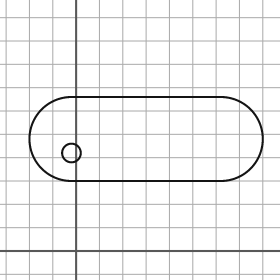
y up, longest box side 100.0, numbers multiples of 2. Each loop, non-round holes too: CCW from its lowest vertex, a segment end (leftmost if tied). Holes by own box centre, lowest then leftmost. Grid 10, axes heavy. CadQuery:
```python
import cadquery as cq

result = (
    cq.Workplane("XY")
    .moveTo(-2.0, 30.0)
    .lineTo(62.0, 30.0)
    .threePointArc((80.0, 48.0), (62.0, 66.0))
    .lineTo(-2.0, 66.0)
    .threePointArc((-20.0, 48.0), (-2.0, 30.0))
    .close()
    .moveTo(-2.0, 42.0)
    .circle(4.0)
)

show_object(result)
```